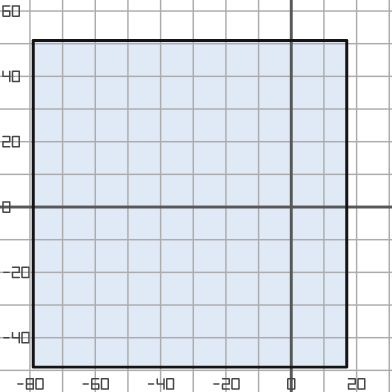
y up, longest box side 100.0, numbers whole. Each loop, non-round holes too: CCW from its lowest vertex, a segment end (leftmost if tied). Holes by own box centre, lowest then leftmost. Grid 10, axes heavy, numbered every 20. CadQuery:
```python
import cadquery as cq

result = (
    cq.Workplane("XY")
    .moveTo(-79.0, -49.0)
    .lineTo(17.0, -49.0)
    .lineTo(17.0, 51.0)
    .lineTo(-79.0, 51.0)
    .close()
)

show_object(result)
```